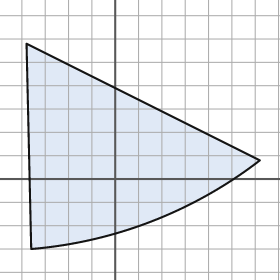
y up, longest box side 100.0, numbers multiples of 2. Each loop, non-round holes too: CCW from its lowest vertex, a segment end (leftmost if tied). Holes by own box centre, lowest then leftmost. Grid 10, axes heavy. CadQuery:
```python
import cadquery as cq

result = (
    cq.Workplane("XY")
    .moveTo(-36.0, -30.0)
    .threePointArc((16.0, -18.0), (62.0, 8.0))
    .lineTo(-38.0, 58.0)
    .close()
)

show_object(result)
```